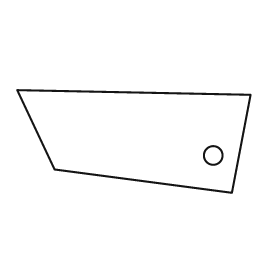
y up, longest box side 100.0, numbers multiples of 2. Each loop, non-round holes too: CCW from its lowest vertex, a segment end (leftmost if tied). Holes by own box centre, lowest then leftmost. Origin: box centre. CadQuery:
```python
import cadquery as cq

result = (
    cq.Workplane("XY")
    .moveTo(42.0, -22.0)
    .lineTo(50.0, 20.0)
    .lineTo(-50.0, 22.0)
    .lineTo(-34.0, -12.0)
    .close()
    .moveTo(34.0, -6.0)
    .circle(4.0)
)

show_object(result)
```